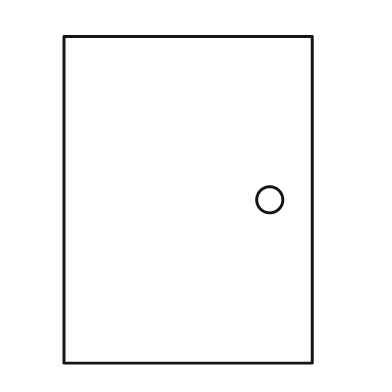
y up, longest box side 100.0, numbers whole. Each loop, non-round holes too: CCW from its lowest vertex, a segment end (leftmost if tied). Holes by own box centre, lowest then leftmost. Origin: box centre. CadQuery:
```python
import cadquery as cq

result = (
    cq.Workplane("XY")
    .moveTo(-38.0, -50.0)
    .lineTo(38.0, -50.0)
    .lineTo(38.0, 50.0)
    .lineTo(-38.0, 50.0)
    .close()
    .moveTo(25.0, 0.0)
    .circle(4.0)
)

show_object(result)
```